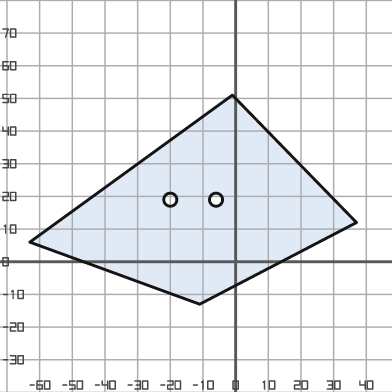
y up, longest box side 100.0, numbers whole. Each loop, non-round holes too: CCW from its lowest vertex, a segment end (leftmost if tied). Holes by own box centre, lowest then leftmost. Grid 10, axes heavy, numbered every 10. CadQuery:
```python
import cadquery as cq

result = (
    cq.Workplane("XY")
    .moveTo(-11.0, -13.0)
    .lineTo(37.0, 12.0)
    .lineTo(-1.0, 51.0)
    .lineTo(-63.0, 6.0)
    .close()
    .moveTo(-20.0, 19.0)
    .circle(2.0)
    .moveTo(-6.0, 19.0)
    .circle(2.0)
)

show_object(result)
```